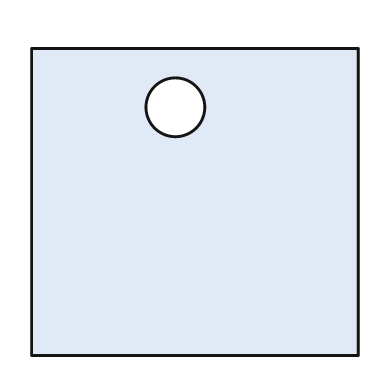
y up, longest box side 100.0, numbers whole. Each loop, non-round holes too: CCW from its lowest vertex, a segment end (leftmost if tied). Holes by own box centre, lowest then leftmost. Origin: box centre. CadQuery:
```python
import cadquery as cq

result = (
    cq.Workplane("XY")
    .moveTo(-50.0, -47.0)
    .lineTo(50.0, -47.0)
    .lineTo(50.0, 47.0)
    .lineTo(-50.0, 47.0)
    .close()
    .moveTo(-6.0, 29.0)
    .circle(9.0)
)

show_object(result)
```